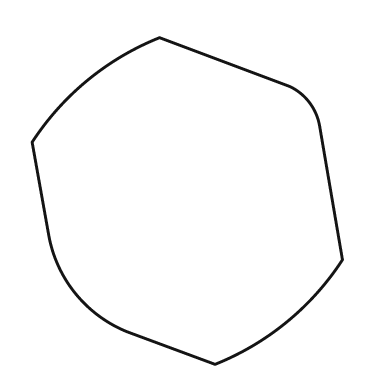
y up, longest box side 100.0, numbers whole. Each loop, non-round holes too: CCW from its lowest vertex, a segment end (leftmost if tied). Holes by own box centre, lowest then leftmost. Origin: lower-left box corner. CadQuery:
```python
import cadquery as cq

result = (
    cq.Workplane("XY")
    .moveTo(56.0, 0.0)
    .threePointArc((78.0, 13.0), (95.0, 32.0))
    .lineTo(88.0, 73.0)
    .threePointArc((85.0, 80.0), (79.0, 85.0))
    .lineTo(39.0, 100.0)
    .threePointArc((17.0, 87.0), (0.0, 68.0))
    .lineTo(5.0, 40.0)
    .threePointArc((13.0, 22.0), (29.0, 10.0))
    .close()
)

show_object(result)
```